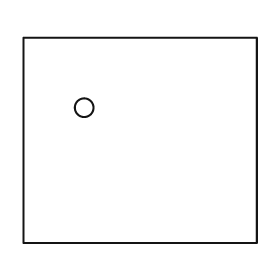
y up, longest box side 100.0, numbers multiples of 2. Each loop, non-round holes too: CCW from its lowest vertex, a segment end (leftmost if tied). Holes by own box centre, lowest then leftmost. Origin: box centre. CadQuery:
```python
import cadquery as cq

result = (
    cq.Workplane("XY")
    .moveTo(-50.0, -44.0)
    .lineTo(50.0, -44.0)
    .lineTo(50.0, 44.0)
    .lineTo(-50.0, 44.0)
    .close()
    .moveTo(-24.0, 14.0)
    .circle(4.0)
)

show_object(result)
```